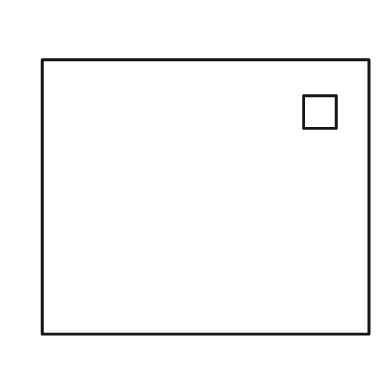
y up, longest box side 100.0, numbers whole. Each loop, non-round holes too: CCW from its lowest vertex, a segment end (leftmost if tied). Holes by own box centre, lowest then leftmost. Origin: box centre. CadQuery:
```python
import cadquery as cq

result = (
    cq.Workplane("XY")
    .moveTo(-50.0, -42.0)
    .lineTo(50.0, -42.0)
    .lineTo(50.0, 42.0)
    .lineTo(-50.0, 42.0)
    .close()
    .moveTo(30.0, 21.0)
    .lineTo(40.0, 21.0)
    .lineTo(40.0, 31.0)
    .lineTo(30.0, 31.0)
    .close()
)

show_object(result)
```